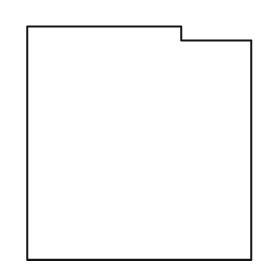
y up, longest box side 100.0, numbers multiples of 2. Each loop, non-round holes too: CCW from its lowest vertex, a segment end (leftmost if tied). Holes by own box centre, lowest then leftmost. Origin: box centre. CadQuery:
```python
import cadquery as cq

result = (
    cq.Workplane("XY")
    .moveTo(-48.0, -50.0)
    .lineTo(48.0, -50.0)
    .lineTo(48.0, 44.0)
    .lineTo(18.0, 44.0)
    .lineTo(18.0, 50.0)
    .lineTo(-48.0, 50.0)
    .close()
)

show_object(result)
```